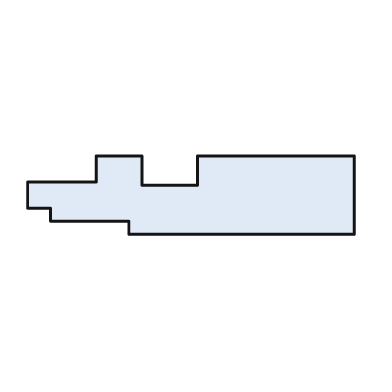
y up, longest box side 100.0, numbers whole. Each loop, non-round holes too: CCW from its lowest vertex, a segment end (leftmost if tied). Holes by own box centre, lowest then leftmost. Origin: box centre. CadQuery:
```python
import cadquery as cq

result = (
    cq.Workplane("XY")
    .moveTo(-19.0, -12.0)
    .lineTo(50.0, -12.0)
    .lineTo(50.0, 12.0)
    .lineTo(2.0, 12.0)
    .lineTo(2.0, 3.0)
    .lineTo(-15.0, 3.0)
    .lineTo(-15.0, 12.0)
    .lineTo(-29.0, 12.0)
    .lineTo(-29.0, 4.0)
    .lineTo(-50.0, 4.0)
    .lineTo(-50.0, -4.0)
    .lineTo(-43.0, -4.0)
    .lineTo(-43.0, -8.0)
    .lineTo(-19.0, -8.0)
    .close()
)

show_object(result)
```